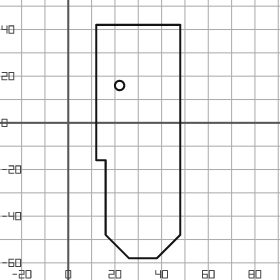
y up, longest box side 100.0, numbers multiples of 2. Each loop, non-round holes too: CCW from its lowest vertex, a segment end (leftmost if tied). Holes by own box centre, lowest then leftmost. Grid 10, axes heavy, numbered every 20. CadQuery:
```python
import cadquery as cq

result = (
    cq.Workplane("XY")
    .moveTo(26.0, -58.0)
    .lineTo(38.0, -58.0)
    .lineTo(48.0, -48.0)
    .lineTo(48.0, 42.0)
    .lineTo(12.0, 42.0)
    .lineTo(12.0, -16.0)
    .lineTo(16.0, -16.0)
    .lineTo(16.0, -48.0)
    .close()
    .moveTo(22.0, 16.0)
    .circle(2.0)
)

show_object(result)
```